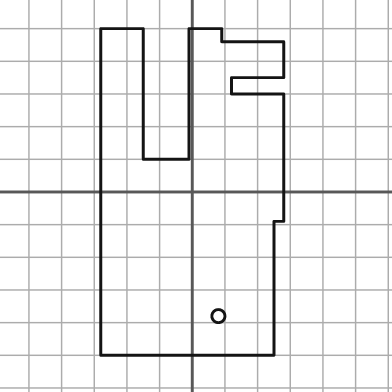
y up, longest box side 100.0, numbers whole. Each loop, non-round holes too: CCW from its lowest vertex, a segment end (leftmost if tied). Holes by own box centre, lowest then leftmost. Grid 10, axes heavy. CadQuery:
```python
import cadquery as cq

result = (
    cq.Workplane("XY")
    .moveTo(-28.0, -50.0)
    .lineTo(25.0, -50.0)
    .lineTo(25.0, -9.0)
    .lineTo(28.0, -9.0)
    .lineTo(28.0, 30.0)
    .lineTo(12.0, 30.0)
    .lineTo(12.0, 35.0)
    .lineTo(28.0, 35.0)
    .lineTo(28.0, 46.0)
    .lineTo(9.0, 46.0)
    .lineTo(9.0, 50.0)
    .lineTo(-1.0, 50.0)
    .lineTo(-1.0, 10.0)
    .lineTo(-15.0, 10.0)
    .lineTo(-15.0, 50.0)
    .lineTo(-28.0, 50.0)
    .close()
    .moveTo(8.0, -38.0)
    .circle(2.0)
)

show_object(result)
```